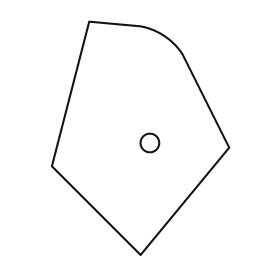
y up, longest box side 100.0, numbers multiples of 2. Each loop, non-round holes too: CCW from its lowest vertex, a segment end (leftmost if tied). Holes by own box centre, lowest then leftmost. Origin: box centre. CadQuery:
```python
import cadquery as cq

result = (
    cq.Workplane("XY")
    .moveTo(0.0, -50.0)
    .lineTo(38.0, -4.0)
    .lineTo(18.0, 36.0)
    .threePointArc((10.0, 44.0), (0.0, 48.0))
    .lineTo(-22.0, 50.0)
    .lineTo(-38.0, -12.0)
    .close()
    .moveTo(4.0, -2.0)
    .circle(4.0)
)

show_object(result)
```